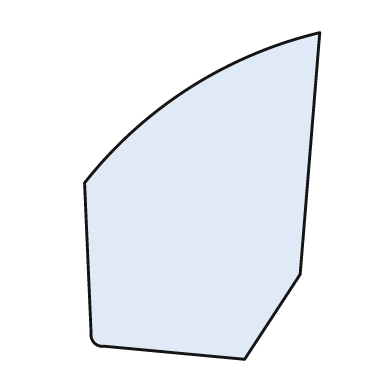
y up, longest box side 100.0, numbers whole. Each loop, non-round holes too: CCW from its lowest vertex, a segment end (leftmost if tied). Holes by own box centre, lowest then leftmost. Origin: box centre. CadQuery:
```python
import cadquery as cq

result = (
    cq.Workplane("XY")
    .moveTo(13.0, -50.0)
    .lineTo(30.0, -24.0)
    .lineTo(36.0, 50.0)
    .threePointArc((-4.0, 33.0), (-36.0, 4.0))
    .lineTo(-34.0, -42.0)
    .threePointArc((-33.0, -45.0), (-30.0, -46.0))
    .close()
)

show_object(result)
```